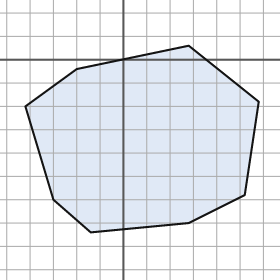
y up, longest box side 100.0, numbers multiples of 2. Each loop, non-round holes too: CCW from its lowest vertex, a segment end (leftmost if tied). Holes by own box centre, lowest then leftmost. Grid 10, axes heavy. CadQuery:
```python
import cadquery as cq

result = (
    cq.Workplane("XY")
    .moveTo(-14.0, -74.0)
    .lineTo(28.0, -70.0)
    .lineTo(52.0, -58.0)
    .lineTo(58.0, -18.0)
    .lineTo(28.0, 6.0)
    .lineTo(-20.0, -4.0)
    .lineTo(-42.0, -20.0)
    .lineTo(-30.0, -60.0)
    .close()
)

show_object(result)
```